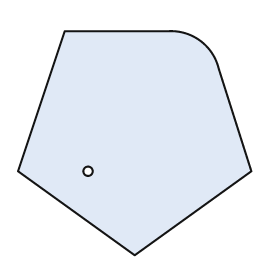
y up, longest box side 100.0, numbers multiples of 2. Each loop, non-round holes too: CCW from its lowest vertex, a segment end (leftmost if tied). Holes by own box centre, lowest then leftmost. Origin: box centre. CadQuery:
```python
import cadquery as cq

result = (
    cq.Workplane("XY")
    .moveTo(0.0, -48.0)
    .lineTo(50.0, -12.0)
    .lineTo(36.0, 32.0)
    .threePointArc((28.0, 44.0), (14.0, 48.0))
    .lineTo(-30.0, 48.0)
    .lineTo(-50.0, -12.0)
    .close()
    .moveTo(-20.0, -12.0)
    .circle(2.0)
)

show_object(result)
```